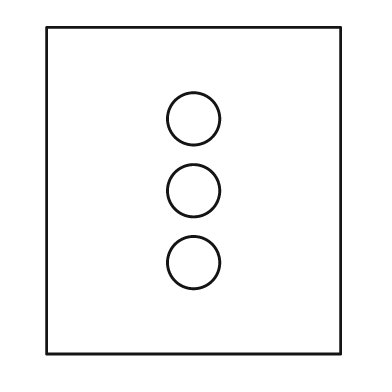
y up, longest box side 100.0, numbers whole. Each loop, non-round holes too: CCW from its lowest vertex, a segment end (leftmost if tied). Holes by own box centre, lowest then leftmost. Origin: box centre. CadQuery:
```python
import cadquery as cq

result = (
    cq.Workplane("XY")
    .moveTo(-45.0, -50.0)
    .lineTo(45.0, -50.0)
    .lineTo(45.0, 50.0)
    .lineTo(-45.0, 50.0)
    .close()
    .moveTo(0.0, -22.0)
    .circle(8.0)
    .moveTo(0.0, 0.0)
    .circle(8.0)
    .moveTo(0.0, 22.0)
    .circle(8.0)
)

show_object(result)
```